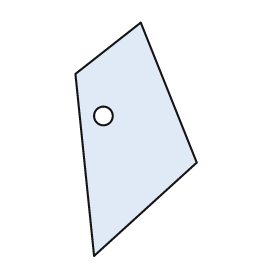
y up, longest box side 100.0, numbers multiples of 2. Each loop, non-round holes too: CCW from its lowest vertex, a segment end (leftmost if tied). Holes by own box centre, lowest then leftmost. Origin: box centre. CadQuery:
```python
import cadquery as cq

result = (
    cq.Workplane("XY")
    .moveTo(-18.0, -50.0)
    .lineTo(26.0, -10.0)
    .lineTo(2.0, 50.0)
    .lineTo(-26.0, 28.0)
    .close()
    .moveTo(-14.0, 10.0)
    .circle(4.0)
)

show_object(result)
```